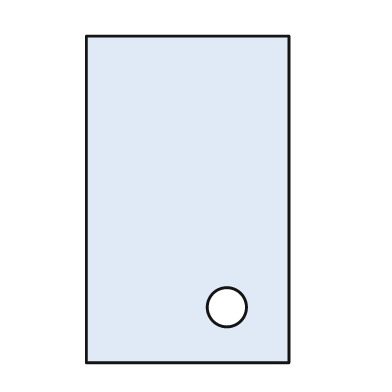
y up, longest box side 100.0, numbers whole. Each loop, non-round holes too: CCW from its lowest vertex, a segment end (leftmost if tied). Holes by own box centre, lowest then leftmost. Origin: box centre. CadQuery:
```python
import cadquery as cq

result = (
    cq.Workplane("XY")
    .moveTo(-31.0, -50.0)
    .lineTo(31.0, -50.0)
    .lineTo(31.0, 50.0)
    .lineTo(-31.0, 50.0)
    .close()
    .moveTo(12.0, -33.0)
    .circle(6.0)
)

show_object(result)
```